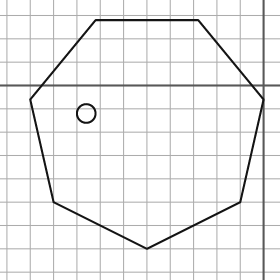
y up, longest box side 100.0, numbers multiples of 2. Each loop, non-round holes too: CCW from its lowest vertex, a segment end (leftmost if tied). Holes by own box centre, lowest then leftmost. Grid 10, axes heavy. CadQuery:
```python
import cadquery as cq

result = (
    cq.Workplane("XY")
    .moveTo(-50.0, -70.0)
    .lineTo(-10.0, -50.0)
    .lineTo(0.0, -6.0)
    .lineTo(-28.0, 28.0)
    .lineTo(-72.0, 28.0)
    .lineTo(-100.0, -6.0)
    .lineTo(-90.0, -50.0)
    .close()
    .moveTo(-76.0, -12.0)
    .circle(4.0)
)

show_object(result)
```